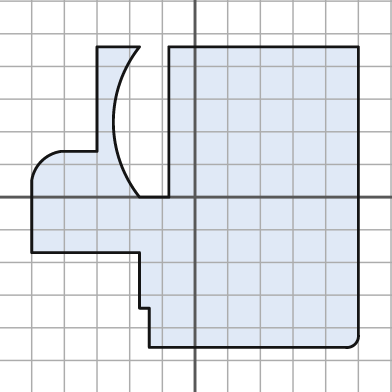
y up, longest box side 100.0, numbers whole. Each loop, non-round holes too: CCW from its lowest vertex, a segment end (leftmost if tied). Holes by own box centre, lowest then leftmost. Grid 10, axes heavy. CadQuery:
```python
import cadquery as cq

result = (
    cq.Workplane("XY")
    .moveTo(-14.0, -46.0)
    .lineTo(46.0, -46.0)
    .threePointArc((49.0, -45.0), (50.0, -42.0))
    .lineTo(50.0, 46.0)
    .lineTo(-8.0, 46.0)
    .lineTo(-8.0, 0.0)
    .lineTo(-17.0, 0.0)
    .threePointArc((-25.0, 23.0), (-17.0, 46.0))
    .lineTo(-30.0, 46.0)
    .lineTo(-30.0, 14.0)
    .lineTo(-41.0, 14.0)
    .threePointArc((-47.0, 11.0), (-50.0, 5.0))
    .lineTo(-50.0, -17.0)
    .lineTo(-17.0, -17.0)
    .lineTo(-17.0, -34.0)
    .lineTo(-14.0, -34.0)
    .close()
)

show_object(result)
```